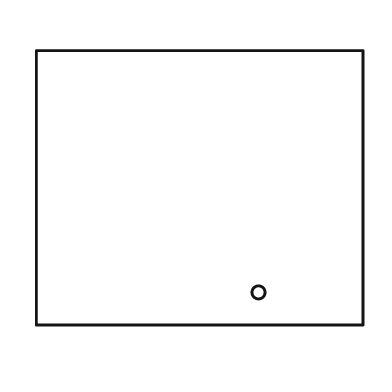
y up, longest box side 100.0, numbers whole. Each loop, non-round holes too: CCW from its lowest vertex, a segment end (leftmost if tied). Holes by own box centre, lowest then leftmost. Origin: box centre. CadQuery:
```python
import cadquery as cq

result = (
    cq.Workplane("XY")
    .moveTo(-50.0, -42.0)
    .lineTo(50.0, -42.0)
    .lineTo(50.0, 42.0)
    .lineTo(-50.0, 42.0)
    .close()
    .moveTo(18.0, -32.0)
    .circle(2.0)
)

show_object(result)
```